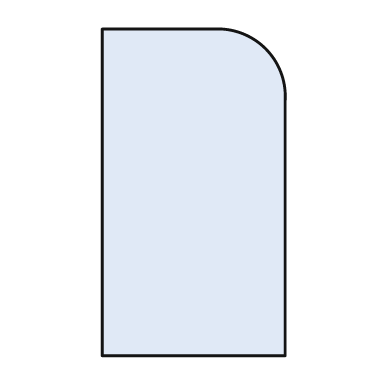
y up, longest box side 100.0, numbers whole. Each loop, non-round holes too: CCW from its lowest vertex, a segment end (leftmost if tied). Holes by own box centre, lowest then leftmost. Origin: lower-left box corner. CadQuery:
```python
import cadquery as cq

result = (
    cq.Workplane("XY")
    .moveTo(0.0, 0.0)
    .lineTo(56.0, 0.0)
    .lineTo(56.0, 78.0)
    .threePointArc((50.0, 94.0), (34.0, 100.0))
    .lineTo(0.0, 100.0)
    .close()
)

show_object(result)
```